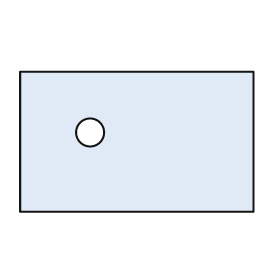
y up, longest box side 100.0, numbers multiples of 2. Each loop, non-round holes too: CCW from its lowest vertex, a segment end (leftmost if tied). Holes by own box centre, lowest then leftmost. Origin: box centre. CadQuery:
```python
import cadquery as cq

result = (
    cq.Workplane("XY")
    .moveTo(-50.0, -30.0)
    .lineTo(50.0, -30.0)
    .lineTo(50.0, 30.0)
    .lineTo(-50.0, 30.0)
    .close()
    .moveTo(-20.0, 4.0)
    .circle(6.0)
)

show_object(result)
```